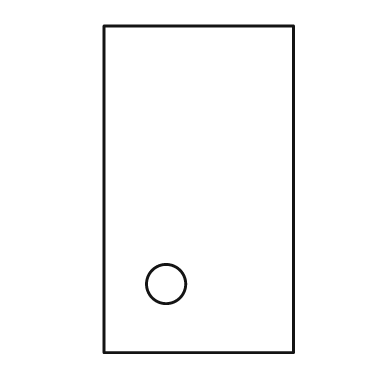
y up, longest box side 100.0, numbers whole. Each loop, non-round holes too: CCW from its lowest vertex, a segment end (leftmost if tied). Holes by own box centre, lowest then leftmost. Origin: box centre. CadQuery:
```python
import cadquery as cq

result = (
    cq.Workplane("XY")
    .moveTo(-29.0, -50.0)
    .lineTo(29.0, -50.0)
    .lineTo(29.0, 50.0)
    .lineTo(-29.0, 50.0)
    .close()
    .moveTo(-10.0, -29.0)
    .circle(6.0)
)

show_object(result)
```